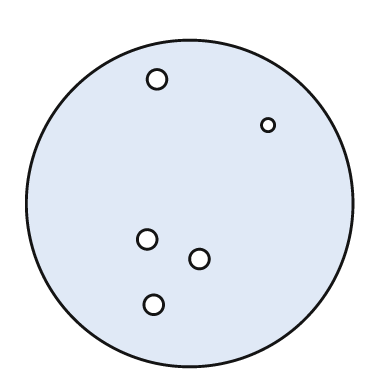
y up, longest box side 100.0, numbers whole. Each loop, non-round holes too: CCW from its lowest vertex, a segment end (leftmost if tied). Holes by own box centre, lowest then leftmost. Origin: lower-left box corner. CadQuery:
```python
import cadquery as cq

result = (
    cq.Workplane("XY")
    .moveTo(50.0, 50.0)
    .circle(50.0)
    .moveTo(39.0, 19.0)
    .circle(3.0)
    .moveTo(53.0, 33.0)
    .circle(3.0)
    .moveTo(37.0, 39.0)
    .circle(3.0)
    .moveTo(74.0, 74.0)
    .circle(2.0)
    .moveTo(40.0, 88.0)
    .circle(3.0)
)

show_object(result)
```